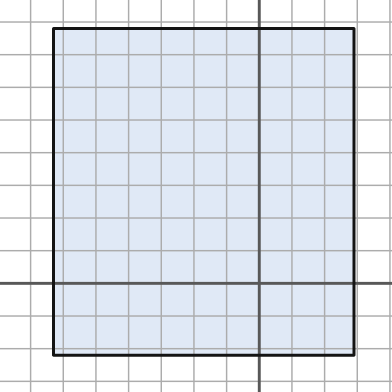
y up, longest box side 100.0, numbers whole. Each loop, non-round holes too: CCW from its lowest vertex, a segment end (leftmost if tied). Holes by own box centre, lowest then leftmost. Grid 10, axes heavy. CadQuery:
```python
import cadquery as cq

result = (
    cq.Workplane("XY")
    .moveTo(-63.0, -22.0)
    .lineTo(29.0, -22.0)
    .lineTo(29.0, 78.0)
    .lineTo(-63.0, 78.0)
    .close()
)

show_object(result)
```